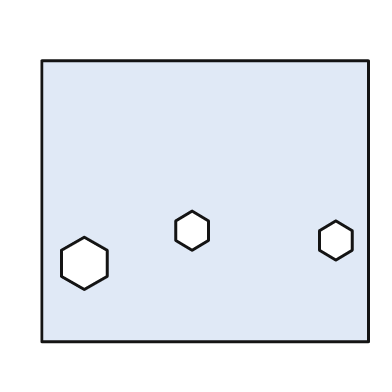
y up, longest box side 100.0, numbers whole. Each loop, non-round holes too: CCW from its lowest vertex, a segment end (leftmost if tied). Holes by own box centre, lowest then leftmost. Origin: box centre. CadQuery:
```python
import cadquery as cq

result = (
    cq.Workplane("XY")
    .moveTo(-50.0, -43.0)
    .lineTo(50.0, -43.0)
    .lineTo(50.0, 43.0)
    .lineTo(-50.0, 43.0)
    .close()
    .moveTo(-37.0, -27.0)
    .lineTo(-30.0, -23.0)
    .lineTo(-30.0, -15.0)
    .lineTo(-37.0, -11.0)
    .lineTo(-44.0, -15.0)
    .lineTo(-44.0, -23.0)
    .close()
    .moveTo(40.0, -18.0)
    .lineTo(45.0, -15.0)
    .lineTo(45.0, -9.0)
    .lineTo(40.0, -6.0)
    .lineTo(35.0, -9.0)
    .lineTo(35.0, -15.0)
    .close()
    .moveTo(-4.0, -15.0)
    .lineTo(1.0, -12.0)
    .lineTo(1.0, -6.0)
    .lineTo(-4.0, -3.0)
    .lineTo(-9.0, -6.0)
    .lineTo(-9.0, -12.0)
    .close()
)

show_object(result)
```